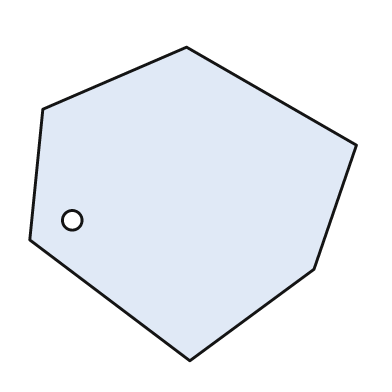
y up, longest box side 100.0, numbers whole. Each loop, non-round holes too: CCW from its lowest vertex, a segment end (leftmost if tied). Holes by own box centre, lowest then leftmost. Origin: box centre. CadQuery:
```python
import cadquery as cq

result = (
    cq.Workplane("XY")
    .moveTo(-1.0, -48.0)
    .lineTo(37.0, -20.0)
    .lineTo(50.0, 18.0)
    .lineTo(-2.0, 48.0)
    .lineTo(-46.0, 29.0)
    .lineTo(-50.0, -11.0)
    .close()
    .moveTo(-37.0, -5.0)
    .circle(3.0)
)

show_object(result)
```